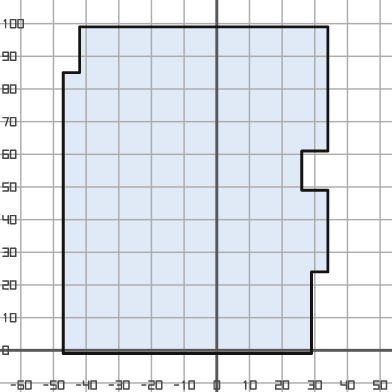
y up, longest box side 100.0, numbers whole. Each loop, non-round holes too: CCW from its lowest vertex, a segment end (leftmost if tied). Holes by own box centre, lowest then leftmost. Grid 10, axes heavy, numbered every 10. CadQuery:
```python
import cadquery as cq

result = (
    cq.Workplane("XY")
    .moveTo(-47.0, -1.0)
    .lineTo(29.0, -1.0)
    .lineTo(29.0, 24.0)
    .lineTo(34.0, 24.0)
    .lineTo(34.0, 49.0)
    .lineTo(26.0, 49.0)
    .lineTo(26.0, 61.0)
    .lineTo(34.0, 61.0)
    .lineTo(34.0, 99.0)
    .lineTo(-42.0, 99.0)
    .lineTo(-42.0, 85.0)
    .lineTo(-47.0, 85.0)
    .close()
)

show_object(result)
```